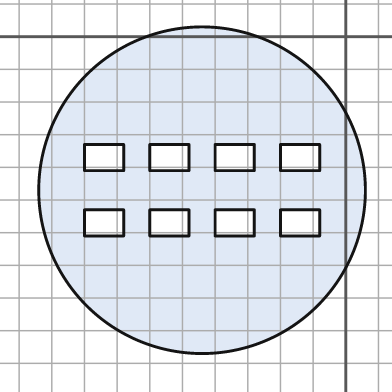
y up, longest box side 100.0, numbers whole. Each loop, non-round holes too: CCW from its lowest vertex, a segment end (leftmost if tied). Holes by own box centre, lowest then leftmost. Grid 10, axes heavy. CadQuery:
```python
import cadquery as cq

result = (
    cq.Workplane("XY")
    .moveTo(-44.0, -47.0)
    .circle(50.0)
    .moveTo(-80.0, -61.0)
    .lineTo(-68.0, -61.0)
    .lineTo(-68.0, -53.0)
    .lineTo(-80.0, -53.0)
    .close()
    .moveTo(-60.0, -61.0)
    .lineTo(-48.0, -61.0)
    .lineTo(-48.0, -53.0)
    .lineTo(-60.0, -53.0)
    .close()
    .moveTo(-40.0, -61.0)
    .lineTo(-28.0, -61.0)
    .lineTo(-28.0, -53.0)
    .lineTo(-40.0, -53.0)
    .close()
    .moveTo(-20.0, -61.0)
    .lineTo(-8.0, -61.0)
    .lineTo(-8.0, -53.0)
    .lineTo(-20.0, -53.0)
    .close()
    .moveTo(-80.0, -41.0)
    .lineTo(-68.0, -41.0)
    .lineTo(-68.0, -33.0)
    .lineTo(-80.0, -33.0)
    .close()
    .moveTo(-60.0, -41.0)
    .lineTo(-48.0, -41.0)
    .lineTo(-48.0, -33.0)
    .lineTo(-60.0, -33.0)
    .close()
    .moveTo(-40.0, -41.0)
    .lineTo(-28.0, -41.0)
    .lineTo(-28.0, -33.0)
    .lineTo(-40.0, -33.0)
    .close()
    .moveTo(-20.0, -41.0)
    .lineTo(-8.0, -41.0)
    .lineTo(-8.0, -33.0)
    .lineTo(-20.0, -33.0)
    .close()
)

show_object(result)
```